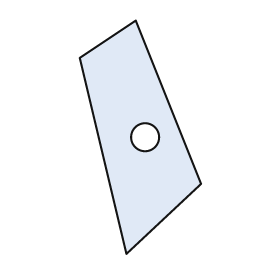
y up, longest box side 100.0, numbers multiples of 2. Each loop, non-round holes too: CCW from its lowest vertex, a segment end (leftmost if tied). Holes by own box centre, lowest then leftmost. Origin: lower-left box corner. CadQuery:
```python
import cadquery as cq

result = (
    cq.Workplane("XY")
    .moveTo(20.0, 0.0)
    .lineTo(52.0, 30.0)
    .lineTo(24.0, 100.0)
    .lineTo(0.0, 84.0)
    .close()
    .moveTo(28.0, 50.0)
    .circle(6.0)
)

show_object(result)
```